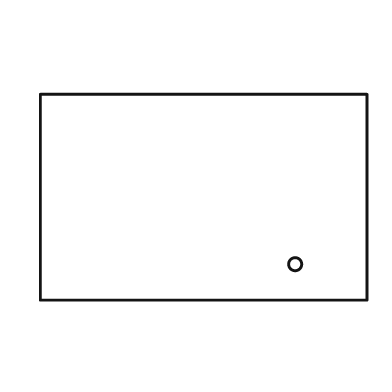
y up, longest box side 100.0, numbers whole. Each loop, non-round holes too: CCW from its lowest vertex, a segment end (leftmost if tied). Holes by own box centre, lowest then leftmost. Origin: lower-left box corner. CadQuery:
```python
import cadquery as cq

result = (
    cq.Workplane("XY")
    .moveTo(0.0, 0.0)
    .lineTo(100.0, 0.0)
    .lineTo(100.0, 63.0)
    .lineTo(0.0, 63.0)
    .close()
    .moveTo(78.0, 11.0)
    .circle(2.0)
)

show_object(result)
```